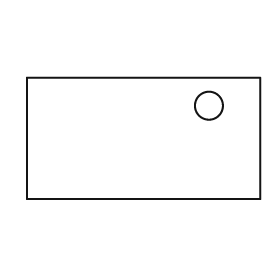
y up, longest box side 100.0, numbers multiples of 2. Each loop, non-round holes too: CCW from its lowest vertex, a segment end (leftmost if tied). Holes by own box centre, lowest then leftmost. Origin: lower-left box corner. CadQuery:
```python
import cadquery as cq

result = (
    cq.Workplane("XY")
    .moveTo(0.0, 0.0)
    .lineTo(100.0, 0.0)
    .lineTo(100.0, 52.0)
    .lineTo(0.0, 52.0)
    .close()
    .moveTo(78.0, 40.0)
    .circle(6.0)
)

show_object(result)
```